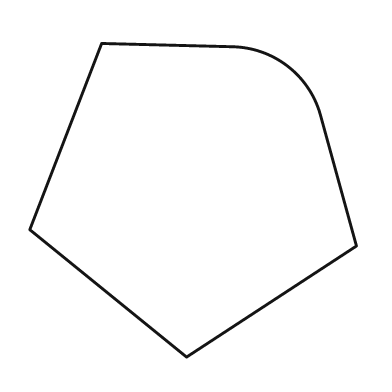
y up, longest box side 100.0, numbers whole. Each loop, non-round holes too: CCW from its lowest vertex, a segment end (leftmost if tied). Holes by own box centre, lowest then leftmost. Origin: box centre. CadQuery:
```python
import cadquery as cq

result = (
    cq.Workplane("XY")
    .moveTo(-2.0, -48.0)
    .lineTo(50.0, -14.0)
    .lineTo(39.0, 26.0)
    .threePointArc((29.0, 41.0), (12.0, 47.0))
    .lineTo(-28.0, 48.0)
    .lineTo(-50.0, -9.0)
    .close()
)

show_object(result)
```